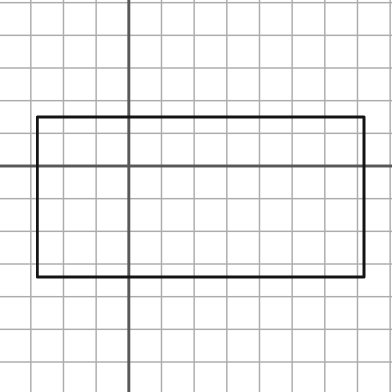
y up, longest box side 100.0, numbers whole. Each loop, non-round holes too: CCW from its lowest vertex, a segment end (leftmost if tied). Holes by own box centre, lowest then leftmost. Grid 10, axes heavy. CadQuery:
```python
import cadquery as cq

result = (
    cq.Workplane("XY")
    .moveTo(-28.0, -34.0)
    .lineTo(72.0, -34.0)
    .lineTo(72.0, 15.0)
    .lineTo(-28.0, 15.0)
    .close()
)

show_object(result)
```